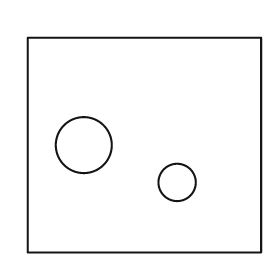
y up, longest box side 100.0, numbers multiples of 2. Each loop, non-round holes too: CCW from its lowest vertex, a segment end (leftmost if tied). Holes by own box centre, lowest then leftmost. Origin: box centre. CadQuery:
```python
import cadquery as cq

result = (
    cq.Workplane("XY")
    .moveTo(-50.0, -46.0)
    .lineTo(50.0, -46.0)
    .lineTo(50.0, 46.0)
    .lineTo(-50.0, 46.0)
    .close()
    .moveTo(14.0, -16.0)
    .circle(8.0)
    .moveTo(-26.0, 0.0)
    .circle(12.0)
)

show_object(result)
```